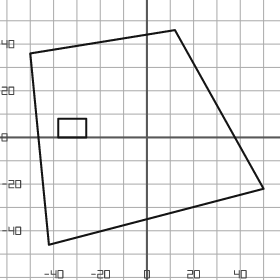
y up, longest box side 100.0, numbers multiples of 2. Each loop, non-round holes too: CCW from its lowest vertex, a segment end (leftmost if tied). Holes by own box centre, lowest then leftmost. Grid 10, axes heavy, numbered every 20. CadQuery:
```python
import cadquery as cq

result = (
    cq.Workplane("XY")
    .moveTo(-42.0, -46.0)
    .lineTo(50.0, -22.0)
    .lineTo(12.0, 46.0)
    .lineTo(-50.0, 36.0)
    .close()
    .moveTo(-38.0, 0.0)
    .lineTo(-26.0, 0.0)
    .lineTo(-26.0, 8.0)
    .lineTo(-38.0, 8.0)
    .close()
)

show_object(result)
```